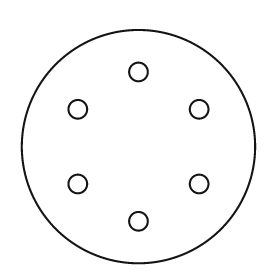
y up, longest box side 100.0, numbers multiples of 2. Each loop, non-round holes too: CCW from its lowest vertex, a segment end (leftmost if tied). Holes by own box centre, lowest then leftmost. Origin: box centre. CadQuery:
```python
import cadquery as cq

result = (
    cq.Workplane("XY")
    .moveTo(0.0, 0.0)
    .circle(50.0)
    .moveTo(0.0, -32.0)
    .circle(4.0)
    .moveTo(-26.0, -16.0)
    .circle(4.0)
    .moveTo(26.0, -16.0)
    .circle(4.0)
    .moveTo(-26.0, 16.0)
    .circle(4.0)
    .moveTo(26.0, 16.0)
    .circle(4.0)
    .moveTo(0.0, 32.0)
    .circle(4.0)
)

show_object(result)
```